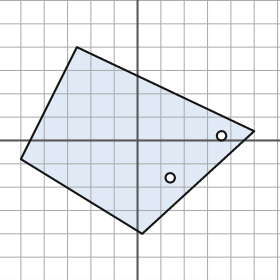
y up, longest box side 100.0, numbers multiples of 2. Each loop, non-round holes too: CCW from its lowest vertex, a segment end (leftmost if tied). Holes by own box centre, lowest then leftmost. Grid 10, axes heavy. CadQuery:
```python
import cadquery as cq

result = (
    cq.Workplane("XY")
    .moveTo(2.0, -40.0)
    .lineTo(50.0, 4.0)
    .lineTo(-26.0, 40.0)
    .lineTo(-50.0, -8.0)
    .close()
    .moveTo(14.0, -16.0)
    .circle(2.0)
    .moveTo(36.0, 2.0)
    .circle(2.0)
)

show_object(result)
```